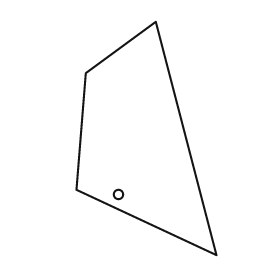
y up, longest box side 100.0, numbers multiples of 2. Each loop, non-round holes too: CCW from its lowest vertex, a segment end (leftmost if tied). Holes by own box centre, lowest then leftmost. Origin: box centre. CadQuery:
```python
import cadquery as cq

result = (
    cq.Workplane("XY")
    .moveTo(30.0, -50.0)
    .lineTo(4.0, 50.0)
    .lineTo(-26.0, 28.0)
    .lineTo(-30.0, -22.0)
    .close()
    .moveTo(-12.0, -24.0)
    .circle(2.0)
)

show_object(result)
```